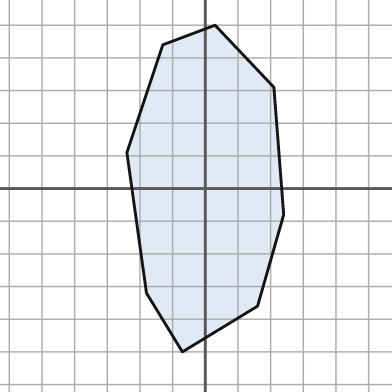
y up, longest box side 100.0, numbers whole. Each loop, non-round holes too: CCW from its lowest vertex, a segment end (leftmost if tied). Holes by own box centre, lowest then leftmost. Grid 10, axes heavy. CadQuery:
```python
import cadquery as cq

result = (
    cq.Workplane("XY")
    .moveTo(-7.0, -50.0)
    .lineTo(16.0, -36.0)
    .lineTo(24.0, -8.0)
    .lineTo(21.0, 31.0)
    .lineTo(3.0, 50.0)
    .lineTo(-13.0, 44.0)
    .lineTo(-24.0, 11.0)
    .lineTo(-18.0, -32.0)
    .close()
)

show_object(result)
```